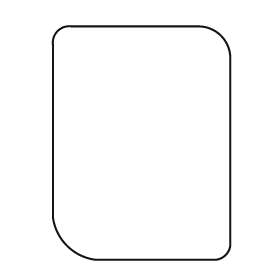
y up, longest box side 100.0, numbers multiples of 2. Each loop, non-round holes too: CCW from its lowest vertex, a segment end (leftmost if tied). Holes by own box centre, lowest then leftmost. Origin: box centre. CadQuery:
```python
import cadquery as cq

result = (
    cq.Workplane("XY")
    .moveTo(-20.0, -50.0)
    .lineTo(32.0, -50.0)
    .threePointArc((36.0, -48.0), (38.0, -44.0))
    .lineTo(38.0, 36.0)
    .threePointArc((34.0, 46.0), (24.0, 50.0))
    .lineTo(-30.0, 50.0)
    .threePointArc((-36.0, 48.0), (-38.0, 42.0))
    .lineTo(-38.0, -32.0)
    .threePointArc((-32.0, -44.0), (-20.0, -50.0))
    .close()
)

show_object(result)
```